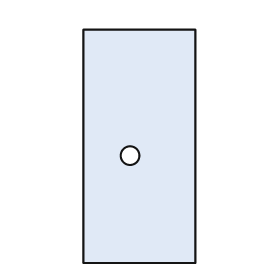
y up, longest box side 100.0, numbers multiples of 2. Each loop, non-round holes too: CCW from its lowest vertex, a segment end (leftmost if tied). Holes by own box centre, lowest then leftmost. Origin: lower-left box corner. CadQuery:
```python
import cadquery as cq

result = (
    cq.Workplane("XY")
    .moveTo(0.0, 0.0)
    .lineTo(48.0, 0.0)
    .lineTo(48.0, 100.0)
    .lineTo(0.0, 100.0)
    .close()
    .moveTo(20.0, 46.0)
    .circle(4.0)
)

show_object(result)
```